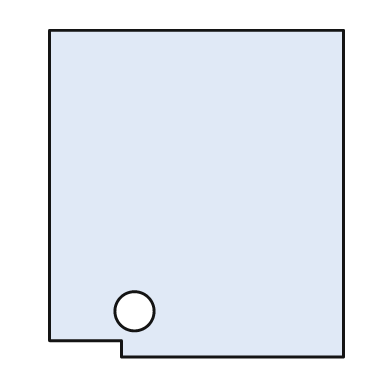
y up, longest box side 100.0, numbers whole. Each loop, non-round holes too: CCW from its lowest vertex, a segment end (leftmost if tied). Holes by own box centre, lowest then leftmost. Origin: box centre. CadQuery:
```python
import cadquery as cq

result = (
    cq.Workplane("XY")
    .moveTo(-23.0, -50.0)
    .lineTo(45.0, -50.0)
    .lineTo(45.0, 50.0)
    .lineTo(-45.0, 50.0)
    .lineTo(-45.0, -45.0)
    .lineTo(-23.0, -45.0)
    .close()
    .moveTo(-19.0, -36.0)
    .circle(6.0)
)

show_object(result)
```